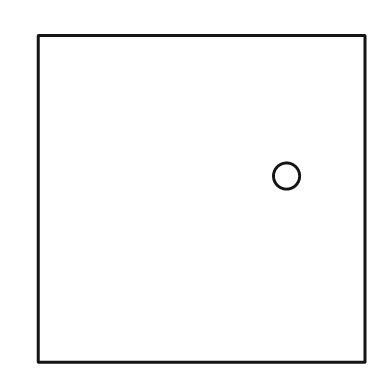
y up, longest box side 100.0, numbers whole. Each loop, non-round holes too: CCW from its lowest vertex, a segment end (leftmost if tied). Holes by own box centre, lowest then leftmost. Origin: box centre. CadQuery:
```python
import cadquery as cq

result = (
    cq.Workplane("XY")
    .moveTo(-50.0, -50.0)
    .lineTo(50.0, -50.0)
    .lineTo(50.0, 50.0)
    .lineTo(-50.0, 50.0)
    .close()
    .moveTo(26.0, 7.0)
    .circle(4.0)
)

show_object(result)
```